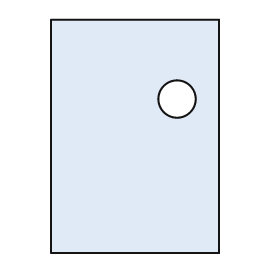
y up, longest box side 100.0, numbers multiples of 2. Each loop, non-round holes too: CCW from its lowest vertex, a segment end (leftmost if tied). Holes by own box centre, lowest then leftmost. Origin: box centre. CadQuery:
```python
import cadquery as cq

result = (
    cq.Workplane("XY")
    .moveTo(-36.0, -50.0)
    .lineTo(36.0, -50.0)
    .lineTo(36.0, 50.0)
    .lineTo(-36.0, 50.0)
    .close()
    .moveTo(18.0, 16.0)
    .circle(8.0)
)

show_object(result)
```